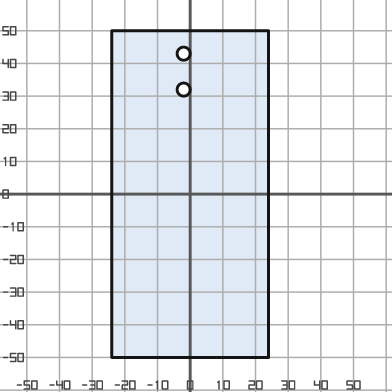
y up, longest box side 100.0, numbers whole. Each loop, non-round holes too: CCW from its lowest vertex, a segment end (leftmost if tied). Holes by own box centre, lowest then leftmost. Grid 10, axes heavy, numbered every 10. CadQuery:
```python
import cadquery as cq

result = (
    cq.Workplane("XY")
    .moveTo(-24.0, -50.0)
    .lineTo(24.0, -50.0)
    .lineTo(24.0, 50.0)
    .lineTo(-24.0, 50.0)
    .close()
    .moveTo(-2.0, 32.0)
    .circle(2.0)
    .moveTo(-2.0, 43.0)
    .circle(2.0)
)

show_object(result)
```